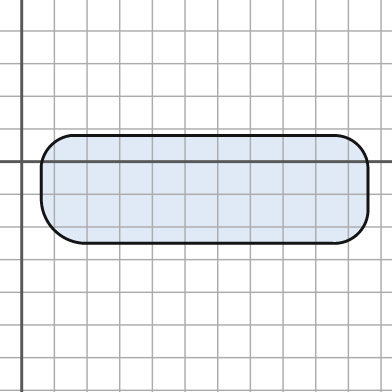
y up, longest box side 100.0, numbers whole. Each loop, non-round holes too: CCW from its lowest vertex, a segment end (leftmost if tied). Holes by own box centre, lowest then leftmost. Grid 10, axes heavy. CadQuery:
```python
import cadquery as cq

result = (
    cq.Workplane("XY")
    .moveTo(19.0, -25.0)
    .lineTo(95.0, -25.0)
    .threePointArc((103.0, -22.0), (106.0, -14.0))
    .lineTo(106.0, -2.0)
    .threePointArc((103.0, 5.0), (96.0, 8.0))
    .lineTo(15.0, 8.0)
    .threePointArc((9.0, 5.0), (6.0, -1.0))
    .lineTo(6.0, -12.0)
    .threePointArc((10.0, -21.0), (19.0, -25.0))
    .close()
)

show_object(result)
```